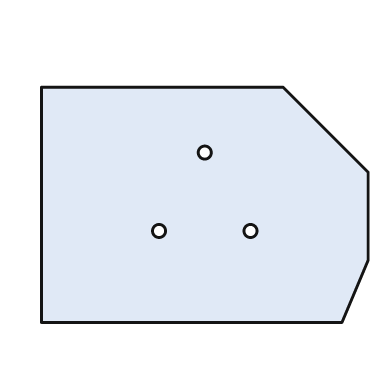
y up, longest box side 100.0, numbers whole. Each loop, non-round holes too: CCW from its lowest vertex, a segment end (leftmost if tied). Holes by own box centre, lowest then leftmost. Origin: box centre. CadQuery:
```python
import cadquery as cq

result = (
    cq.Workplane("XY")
    .moveTo(-50.0, -36.0)
    .lineTo(42.0, -36.0)
    .lineTo(50.0, -17.0)
    .lineTo(50.0, 10.0)
    .lineTo(24.0, 36.0)
    .lineTo(-50.0, 36.0)
    .close()
    .moveTo(-14.0, -8.0)
    .circle(2.0)
    .moveTo(14.0, -8.0)
    .circle(2.0)
    .moveTo(0.0, 16.0)
    .circle(2.0)
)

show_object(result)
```